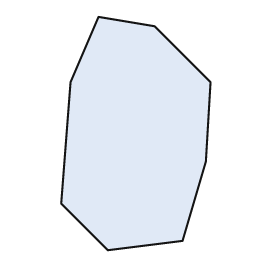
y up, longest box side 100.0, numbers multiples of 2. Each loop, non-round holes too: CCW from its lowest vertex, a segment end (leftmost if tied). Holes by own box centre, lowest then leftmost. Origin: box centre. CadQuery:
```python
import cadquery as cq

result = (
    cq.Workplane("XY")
    .moveTo(-12.0, -50.0)
    .lineTo(20.0, -46.0)
    .lineTo(30.0, -12.0)
    .lineTo(32.0, 22.0)
    .lineTo(8.0, 46.0)
    .lineTo(-16.0, 50.0)
    .lineTo(-28.0, 22.0)
    .lineTo(-32.0, -30.0)
    .close()
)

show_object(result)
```